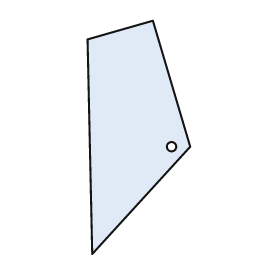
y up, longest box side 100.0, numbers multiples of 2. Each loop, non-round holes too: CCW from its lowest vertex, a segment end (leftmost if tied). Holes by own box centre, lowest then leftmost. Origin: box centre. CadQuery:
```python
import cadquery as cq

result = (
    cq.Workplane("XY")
    .moveTo(-20.0, -50.0)
    .lineTo(22.0, -4.0)
    .lineTo(6.0, 50.0)
    .lineTo(-22.0, 42.0)
    .close()
    .moveTo(14.0, -4.0)
    .circle(2.0)
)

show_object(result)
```